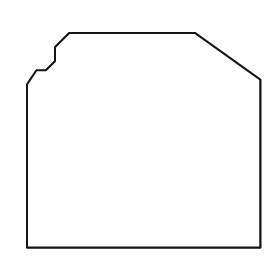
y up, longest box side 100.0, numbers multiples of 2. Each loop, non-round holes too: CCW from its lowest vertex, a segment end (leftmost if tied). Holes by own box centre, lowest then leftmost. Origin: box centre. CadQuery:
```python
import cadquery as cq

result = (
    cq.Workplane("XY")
    .moveTo(-50.0, -46.0)
    .lineTo(50.0, -46.0)
    .lineTo(50.0, 26.0)
    .lineTo(22.0, 46.0)
    .lineTo(-32.0, 46.0)
    .lineTo(-38.0, 40.0)
    .lineTo(-38.0, 34.0)
    .lineTo(-42.0, 30.0)
    .lineTo(-46.0, 30.0)
    .lineTo(-50.0, 24.0)
    .close()
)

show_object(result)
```